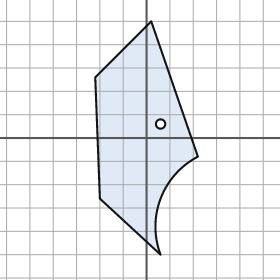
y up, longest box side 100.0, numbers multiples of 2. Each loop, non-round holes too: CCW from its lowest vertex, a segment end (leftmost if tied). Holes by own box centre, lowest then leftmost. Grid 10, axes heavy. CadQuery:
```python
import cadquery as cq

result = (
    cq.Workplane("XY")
    .moveTo(6.0, -50.0)
    .threePointArc((6.0, -26.0), (22.0, -8.0))
    .lineTo(2.0, 50.0)
    .lineTo(-22.0, 26.0)
    .lineTo(-20.0, -26.0)
    .close()
    .moveTo(6.0, 6.0)
    .circle(2.0)
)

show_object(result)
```